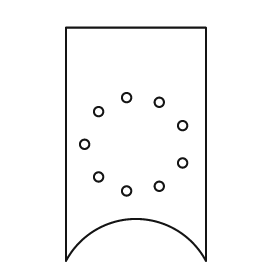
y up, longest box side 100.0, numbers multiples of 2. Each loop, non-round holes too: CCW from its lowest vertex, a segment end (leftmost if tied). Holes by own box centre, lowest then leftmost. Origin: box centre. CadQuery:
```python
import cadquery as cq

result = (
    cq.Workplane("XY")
    .moveTo(-30.0, -50.0)
    .threePointArc((0.0, -32.0), (30.0, -50.0))
    .lineTo(30.0, 50.0)
    .lineTo(-30.0, 50.0)
    .close()
    .moveTo(-4.0, -20.0)
    .circle(2.0)
    .moveTo(10.0, -18.0)
    .circle(2.0)
    .moveTo(-16.0, -14.0)
    .circle(2.0)
    .moveTo(20.0, -8.0)
    .circle(2.0)
    .moveTo(-22.0, 0.0)
    .circle(2.0)
    .moveTo(20.0, 8.0)
    .circle(2.0)
    .moveTo(-16.0, 14.0)
    .circle(2.0)
    .moveTo(10.0, 18.0)
    .circle(2.0)
    .moveTo(-4.0, 20.0)
    .circle(2.0)
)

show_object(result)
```